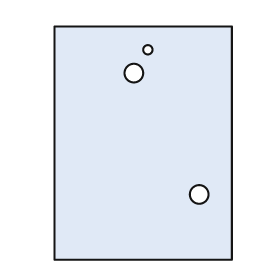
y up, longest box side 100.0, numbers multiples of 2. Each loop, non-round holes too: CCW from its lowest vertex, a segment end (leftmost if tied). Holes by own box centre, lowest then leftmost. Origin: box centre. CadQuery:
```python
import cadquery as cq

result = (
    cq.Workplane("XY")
    .moveTo(-38.0, -50.0)
    .lineTo(38.0, -50.0)
    .lineTo(38.0, 50.0)
    .lineTo(-38.0, 50.0)
    .close()
    .moveTo(24.0, -22.0)
    .circle(4.0)
    .moveTo(-4.0, 30.0)
    .circle(4.0)
    .moveTo(2.0, 40.0)
    .circle(2.0)
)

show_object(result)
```